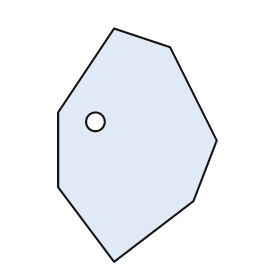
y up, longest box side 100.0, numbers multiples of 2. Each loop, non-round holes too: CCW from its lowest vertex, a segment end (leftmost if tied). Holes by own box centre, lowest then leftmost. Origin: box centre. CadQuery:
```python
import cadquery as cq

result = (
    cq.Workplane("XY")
    .moveTo(-10.0, -50.0)
    .lineTo(24.0, -24.0)
    .lineTo(34.0, 2.0)
    .lineTo(14.0, 42.0)
    .lineTo(-10.0, 50.0)
    .lineTo(-34.0, 14.0)
    .lineTo(-34.0, -18.0)
    .close()
    .moveTo(-18.0, 10.0)
    .circle(4.0)
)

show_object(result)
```